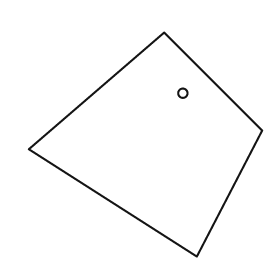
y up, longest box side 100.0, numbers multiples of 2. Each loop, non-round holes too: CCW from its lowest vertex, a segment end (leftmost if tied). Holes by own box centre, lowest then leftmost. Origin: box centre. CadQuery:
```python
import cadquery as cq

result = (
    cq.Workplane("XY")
    .moveTo(22.0, -48.0)
    .lineTo(50.0, 6.0)
    .lineTo(8.0, 48.0)
    .lineTo(-50.0, -2.0)
    .close()
    .moveTo(16.0, 22.0)
    .circle(2.0)
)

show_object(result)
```